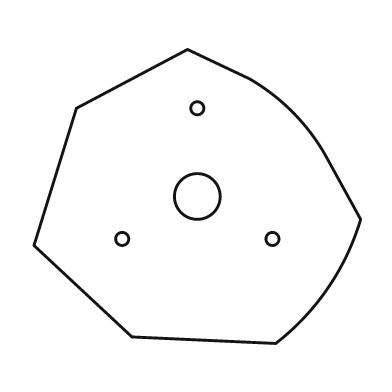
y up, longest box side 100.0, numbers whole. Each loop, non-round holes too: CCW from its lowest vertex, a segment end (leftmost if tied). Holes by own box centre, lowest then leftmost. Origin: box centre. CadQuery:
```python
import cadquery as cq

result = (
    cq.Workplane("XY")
    .moveTo(24.0, -45.0)
    .threePointArc((40.0, -28.0), (50.0, -7.0))
    .lineTo(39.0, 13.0)
    .threePointArc((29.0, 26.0), (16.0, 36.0))
    .lineTo(-3.0, 45.0)
    .lineTo(-37.0, 27.0)
    .lineTo(-50.0, -15.0)
    .lineTo(-20.0, -43.0)
    .close()
    .moveTo(-23.0, -13.0)
    .circle(2.0)
    .moveTo(23.0, -13.0)
    .circle(2.0)
    .moveTo(0.0, 0.0)
    .circle(7.0)
    .moveTo(0.0, 27.0)
    .circle(2.0)
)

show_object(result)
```